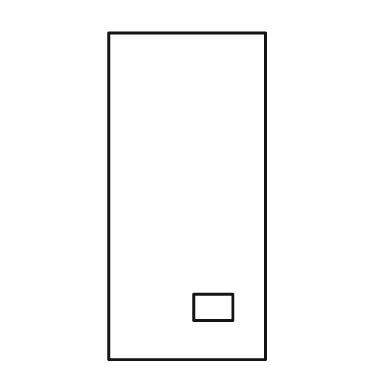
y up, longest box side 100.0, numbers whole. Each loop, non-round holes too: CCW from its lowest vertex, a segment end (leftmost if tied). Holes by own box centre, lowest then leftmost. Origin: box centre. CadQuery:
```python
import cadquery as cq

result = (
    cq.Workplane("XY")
    .moveTo(-24.0, -50.0)
    .lineTo(24.0, -50.0)
    .lineTo(24.0, 50.0)
    .lineTo(-24.0, 50.0)
    .close()
    .moveTo(2.0, -38.0)
    .lineTo(14.0, -38.0)
    .lineTo(14.0, -30.0)
    .lineTo(2.0, -30.0)
    .close()
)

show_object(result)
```